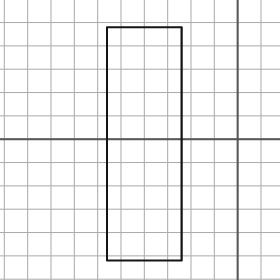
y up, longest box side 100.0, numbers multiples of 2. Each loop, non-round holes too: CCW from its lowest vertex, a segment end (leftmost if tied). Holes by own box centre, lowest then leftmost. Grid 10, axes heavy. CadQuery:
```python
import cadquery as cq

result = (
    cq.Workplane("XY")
    .moveTo(-56.0, -52.0)
    .lineTo(-24.0, -52.0)
    .lineTo(-24.0, 48.0)
    .lineTo(-56.0, 48.0)
    .close()
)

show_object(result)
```